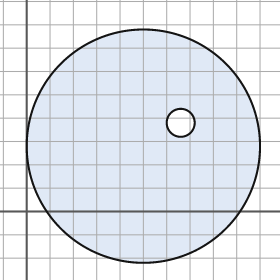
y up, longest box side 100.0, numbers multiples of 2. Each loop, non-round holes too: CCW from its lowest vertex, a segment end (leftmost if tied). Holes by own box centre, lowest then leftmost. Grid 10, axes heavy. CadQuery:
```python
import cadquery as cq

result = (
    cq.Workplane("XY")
    .moveTo(50.0, 28.0)
    .circle(50.0)
    .moveTo(66.0, 38.0)
    .circle(6.0)
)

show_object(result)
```